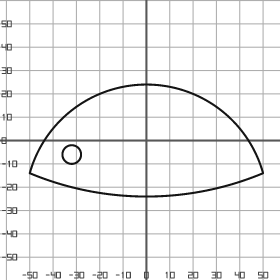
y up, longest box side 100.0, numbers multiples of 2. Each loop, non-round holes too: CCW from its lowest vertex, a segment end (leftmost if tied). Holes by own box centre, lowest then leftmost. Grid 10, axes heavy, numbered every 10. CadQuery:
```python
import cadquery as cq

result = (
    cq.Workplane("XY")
    .moveTo(-50.0, -14.0)
    .threePointArc((0.0, -24.0), (50.0, -14.0))
    .threePointArc((0.0, 24.0), (-50.0, -14.0))
    .close()
    .moveTo(-32.0, -6.0)
    .circle(4.0)
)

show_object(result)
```